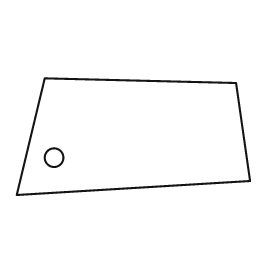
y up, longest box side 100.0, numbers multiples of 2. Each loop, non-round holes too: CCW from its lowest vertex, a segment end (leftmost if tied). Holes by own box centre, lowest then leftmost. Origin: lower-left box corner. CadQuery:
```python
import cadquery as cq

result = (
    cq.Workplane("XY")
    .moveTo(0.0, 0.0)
    .lineTo(100.0, 6.0)
    .lineTo(94.0, 48.0)
    .lineTo(12.0, 50.0)
    .close()
    .moveTo(16.0, 16.0)
    .circle(4.0)
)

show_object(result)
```